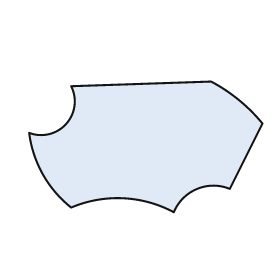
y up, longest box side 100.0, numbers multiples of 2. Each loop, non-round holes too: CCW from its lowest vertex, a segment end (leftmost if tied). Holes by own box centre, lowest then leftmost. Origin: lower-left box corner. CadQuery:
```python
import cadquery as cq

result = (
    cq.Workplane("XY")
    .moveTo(62.0, 0.0)
    .threePointArc((72.0, 10.0), (86.0, 10.0))
    .lineTo(100.0, 38.0)
    .threePointArc((90.0, 48.0), (78.0, 56.0))
    .lineTo(18.0, 54.0)
    .threePointArc((16.0, 38.0), (0.0, 34.0))
    .threePointArc((6.0, 16.0), (18.0, 2.0))
    .threePointArc((40.0, 6.0), (62.0, 0.0))
    .close()
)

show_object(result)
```